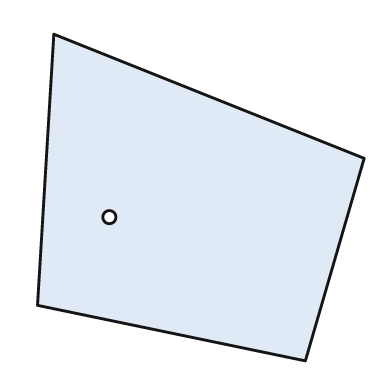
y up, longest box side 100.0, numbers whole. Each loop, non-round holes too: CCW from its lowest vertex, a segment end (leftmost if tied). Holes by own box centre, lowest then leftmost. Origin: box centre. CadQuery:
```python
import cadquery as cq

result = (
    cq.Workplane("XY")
    .moveTo(32.0, -50.0)
    .lineTo(50.0, 12.0)
    .lineTo(-45.0, 50.0)
    .lineTo(-50.0, -33.0)
    .close()
    .moveTo(-28.0, -6.0)
    .circle(2.0)
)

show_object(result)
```